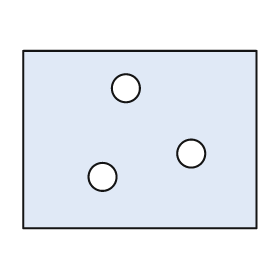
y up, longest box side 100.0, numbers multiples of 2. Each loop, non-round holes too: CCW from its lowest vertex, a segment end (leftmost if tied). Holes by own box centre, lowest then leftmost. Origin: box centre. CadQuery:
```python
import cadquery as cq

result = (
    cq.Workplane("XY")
    .moveTo(-50.0, -38.0)
    .lineTo(50.0, -38.0)
    .lineTo(50.0, 38.0)
    .lineTo(-50.0, 38.0)
    .close()
    .moveTo(-16.0, -16.0)
    .circle(6.0)
    .moveTo(22.0, -6.0)
    .circle(6.0)
    .moveTo(-6.0, 22.0)
    .circle(6.0)
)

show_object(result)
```